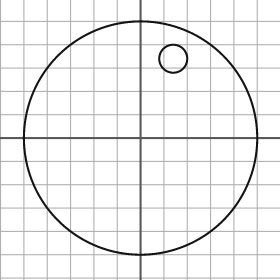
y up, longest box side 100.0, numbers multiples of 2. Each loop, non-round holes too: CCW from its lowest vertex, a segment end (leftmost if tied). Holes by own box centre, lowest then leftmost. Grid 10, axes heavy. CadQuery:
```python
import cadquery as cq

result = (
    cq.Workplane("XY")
    .moveTo(0.0, 0.0)
    .circle(50.0)
    .moveTo(14.0, 34.0)
    .circle(6.0)
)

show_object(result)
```